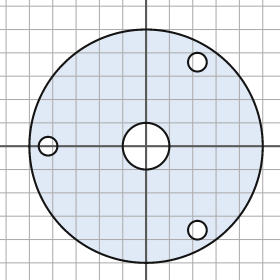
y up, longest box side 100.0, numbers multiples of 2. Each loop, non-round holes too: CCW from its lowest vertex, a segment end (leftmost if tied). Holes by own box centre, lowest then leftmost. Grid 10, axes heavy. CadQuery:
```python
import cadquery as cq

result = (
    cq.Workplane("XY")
    .moveTo(0.0, 0.0)
    .circle(50.0)
    .moveTo(22.0, -36.0)
    .circle(4.0)
    .moveTo(-42.0, 0.0)
    .circle(4.0)
    .moveTo(0.0, 0.0)
    .circle(10.0)
    .moveTo(22.0, 36.0)
    .circle(4.0)
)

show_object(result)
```